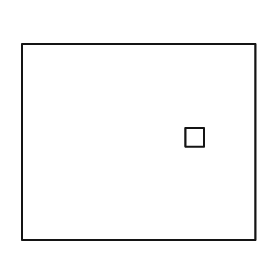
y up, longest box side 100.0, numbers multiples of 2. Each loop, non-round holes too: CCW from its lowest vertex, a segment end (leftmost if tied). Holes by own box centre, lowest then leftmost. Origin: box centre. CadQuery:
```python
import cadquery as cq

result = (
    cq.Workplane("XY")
    .moveTo(-50.0, -42.0)
    .lineTo(50.0, -42.0)
    .lineTo(50.0, 42.0)
    .lineTo(-50.0, 42.0)
    .close()
    .moveTo(20.0, -2.0)
    .lineTo(28.0, -2.0)
    .lineTo(28.0, 6.0)
    .lineTo(20.0, 6.0)
    .close()
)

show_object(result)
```